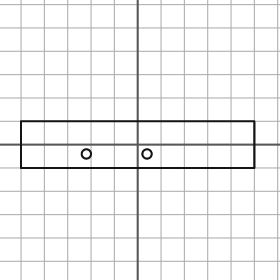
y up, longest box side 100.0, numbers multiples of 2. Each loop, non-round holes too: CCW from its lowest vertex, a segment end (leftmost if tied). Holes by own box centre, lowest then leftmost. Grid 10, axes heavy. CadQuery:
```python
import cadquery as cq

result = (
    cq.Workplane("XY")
    .moveTo(-50.0, -10.0)
    .lineTo(50.0, -10.0)
    .lineTo(50.0, 10.0)
    .lineTo(-50.0, 10.0)
    .close()
    .moveTo(-22.0, -4.0)
    .circle(2.0)
    .moveTo(4.0, -4.0)
    .circle(2.0)
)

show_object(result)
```